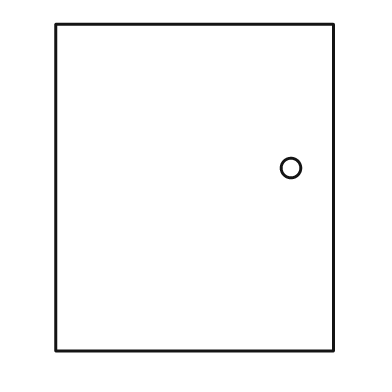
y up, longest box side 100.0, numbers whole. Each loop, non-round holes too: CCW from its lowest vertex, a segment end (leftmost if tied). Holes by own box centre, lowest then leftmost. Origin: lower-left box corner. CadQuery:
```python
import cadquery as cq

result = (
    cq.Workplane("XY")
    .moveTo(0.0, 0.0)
    .lineTo(85.0, 0.0)
    .lineTo(85.0, 100.0)
    .lineTo(0.0, 100.0)
    .close()
    .moveTo(72.0, 56.0)
    .circle(3.0)
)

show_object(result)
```